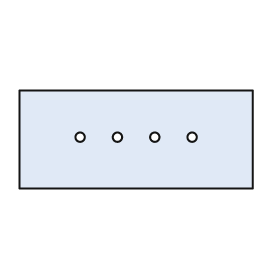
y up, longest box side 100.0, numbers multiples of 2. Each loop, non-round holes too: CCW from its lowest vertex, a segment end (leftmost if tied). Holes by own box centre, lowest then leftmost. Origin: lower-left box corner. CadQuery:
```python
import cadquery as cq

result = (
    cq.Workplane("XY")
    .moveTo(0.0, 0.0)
    .lineTo(100.0, 0.0)
    .lineTo(100.0, 42.0)
    .lineTo(0.0, 42.0)
    .close()
    .moveTo(26.0, 22.0)
    .circle(2.0)
    .moveTo(42.0, 22.0)
    .circle(2.0)
    .moveTo(58.0, 22.0)
    .circle(2.0)
    .moveTo(74.0, 22.0)
    .circle(2.0)
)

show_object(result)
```